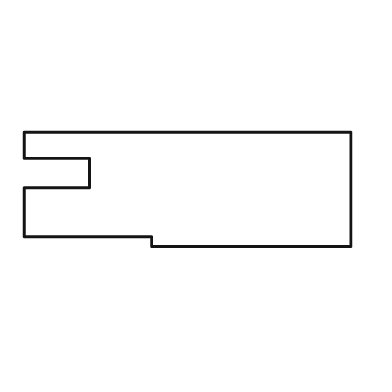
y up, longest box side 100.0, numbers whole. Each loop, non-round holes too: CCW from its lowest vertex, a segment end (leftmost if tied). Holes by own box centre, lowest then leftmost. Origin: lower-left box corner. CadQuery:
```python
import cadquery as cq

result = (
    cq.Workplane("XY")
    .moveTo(39.0, 0.0)
    .lineTo(100.0, 0.0)
    .lineTo(100.0, 35.0)
    .lineTo(0.0, 35.0)
    .lineTo(0.0, 27.0)
    .lineTo(20.0, 27.0)
    .lineTo(20.0, 18.0)
    .lineTo(0.0, 18.0)
    .lineTo(0.0, 3.0)
    .lineTo(39.0, 3.0)
    .close()
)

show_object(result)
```